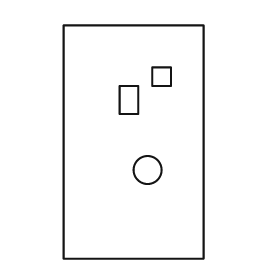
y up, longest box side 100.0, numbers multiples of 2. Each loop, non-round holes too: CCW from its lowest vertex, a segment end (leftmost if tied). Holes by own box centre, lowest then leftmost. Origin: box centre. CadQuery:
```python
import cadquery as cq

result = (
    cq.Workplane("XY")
    .moveTo(-30.0, -50.0)
    .lineTo(30.0, -50.0)
    .lineTo(30.0, 50.0)
    .lineTo(-30.0, 50.0)
    .close()
    .moveTo(6.0, -12.0)
    .circle(6.0)
    .moveTo(-6.0, 12.0)
    .lineTo(2.0, 12.0)
    .lineTo(2.0, 24.0)
    .lineTo(-6.0, 24.0)
    .close()
    .moveTo(8.0, 24.0)
    .lineTo(16.0, 24.0)
    .lineTo(16.0, 32.0)
    .lineTo(8.0, 32.0)
    .close()
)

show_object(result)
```